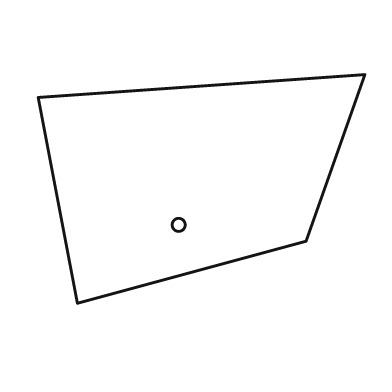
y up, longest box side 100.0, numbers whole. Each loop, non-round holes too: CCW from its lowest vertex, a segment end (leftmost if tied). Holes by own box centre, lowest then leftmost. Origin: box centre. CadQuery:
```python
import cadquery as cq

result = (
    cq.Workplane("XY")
    .moveTo(-38.0, -35.0)
    .lineTo(32.0, -16.0)
    .lineTo(50.0, 35.0)
    .lineTo(-50.0, 28.0)
    .close()
    .moveTo(-7.0, -11.0)
    .circle(2.0)
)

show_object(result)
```